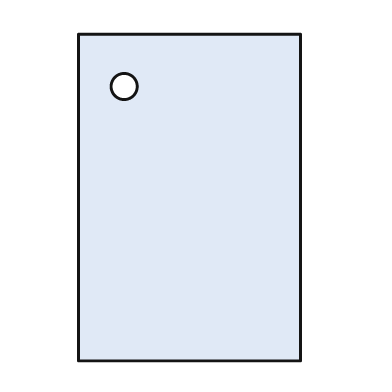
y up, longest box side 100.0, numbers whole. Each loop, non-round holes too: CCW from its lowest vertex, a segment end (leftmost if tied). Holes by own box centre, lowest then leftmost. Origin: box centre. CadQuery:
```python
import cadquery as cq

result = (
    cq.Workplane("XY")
    .moveTo(-34.0, -50.0)
    .lineTo(34.0, -50.0)
    .lineTo(34.0, 50.0)
    .lineTo(-34.0, 50.0)
    .close()
    .moveTo(-20.0, 34.0)
    .circle(4.0)
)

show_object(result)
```